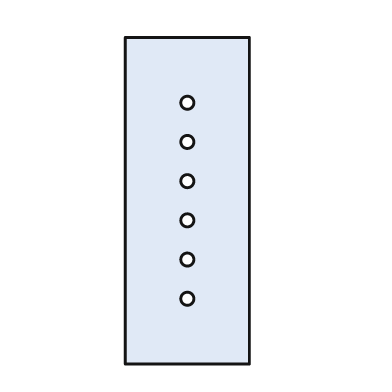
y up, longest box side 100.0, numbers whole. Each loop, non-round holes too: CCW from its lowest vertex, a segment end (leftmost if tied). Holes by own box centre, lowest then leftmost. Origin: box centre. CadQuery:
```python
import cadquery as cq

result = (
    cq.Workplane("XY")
    .moveTo(-19.0, -50.0)
    .lineTo(19.0, -50.0)
    .lineTo(19.0, 50.0)
    .lineTo(-19.0, 50.0)
    .close()
    .moveTo(0.0, -30.0)
    .circle(2.0)
    .moveTo(0.0, -18.0)
    .circle(2.0)
    .moveTo(0.0, -6.0)
    .circle(2.0)
    .moveTo(0.0, 6.0)
    .circle(2.0)
    .moveTo(0.0, 18.0)
    .circle(2.0)
    .moveTo(0.0, 30.0)
    .circle(2.0)
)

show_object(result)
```